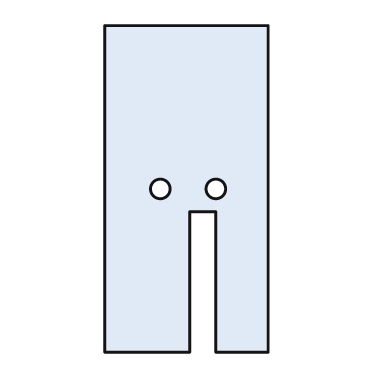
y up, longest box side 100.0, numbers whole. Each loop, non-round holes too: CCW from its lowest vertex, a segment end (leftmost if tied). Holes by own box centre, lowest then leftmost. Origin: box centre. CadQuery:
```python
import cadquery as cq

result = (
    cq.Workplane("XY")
    .moveTo(-25.0, -50.0)
    .lineTo(1.0, -50.0)
    .lineTo(1.0, -7.0)
    .lineTo(9.0, -7.0)
    .lineTo(9.0, -50.0)
    .lineTo(25.0, -50.0)
    .lineTo(25.0, 50.0)
    .lineTo(-25.0, 50.0)
    .close()
    .moveTo(-8.0, 0.0)
    .circle(3.0)
    .moveTo(9.0, 0.0)
    .circle(3.0)
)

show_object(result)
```